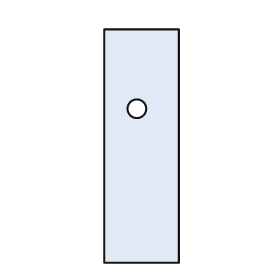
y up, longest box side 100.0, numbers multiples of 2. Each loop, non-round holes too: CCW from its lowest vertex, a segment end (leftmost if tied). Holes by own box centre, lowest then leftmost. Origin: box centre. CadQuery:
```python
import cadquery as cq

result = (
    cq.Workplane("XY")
    .moveTo(-16.0, -50.0)
    .lineTo(16.0, -50.0)
    .lineTo(16.0, 50.0)
    .lineTo(-16.0, 50.0)
    .close()
    .moveTo(-2.0, 16.0)
    .circle(4.0)
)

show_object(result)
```